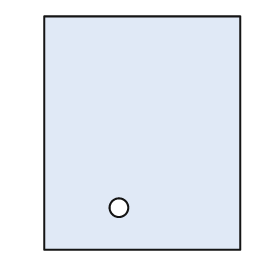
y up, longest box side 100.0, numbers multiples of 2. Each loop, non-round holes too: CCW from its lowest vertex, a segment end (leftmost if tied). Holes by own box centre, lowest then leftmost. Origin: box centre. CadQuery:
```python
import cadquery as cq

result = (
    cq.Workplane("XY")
    .moveTo(-42.0, -50.0)
    .lineTo(42.0, -50.0)
    .lineTo(42.0, 50.0)
    .lineTo(-42.0, 50.0)
    .close()
    .moveTo(-10.0, -32.0)
    .circle(4.0)
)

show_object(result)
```